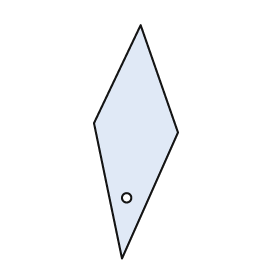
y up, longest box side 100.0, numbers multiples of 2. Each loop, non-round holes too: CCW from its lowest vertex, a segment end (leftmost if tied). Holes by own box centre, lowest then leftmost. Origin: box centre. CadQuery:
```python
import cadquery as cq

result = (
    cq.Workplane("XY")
    .moveTo(-6.0, -50.0)
    .lineTo(18.0, 4.0)
    .lineTo(2.0, 50.0)
    .lineTo(-18.0, 8.0)
    .close()
    .moveTo(-4.0, -24.0)
    .circle(2.0)
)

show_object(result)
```